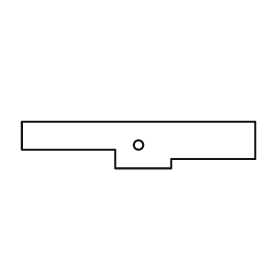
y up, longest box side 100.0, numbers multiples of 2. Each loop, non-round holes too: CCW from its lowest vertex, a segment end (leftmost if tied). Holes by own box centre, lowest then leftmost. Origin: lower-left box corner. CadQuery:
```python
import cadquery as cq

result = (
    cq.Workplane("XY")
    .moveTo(40.0, 0.0)
    .lineTo(64.0, 0.0)
    .lineTo(64.0, 4.0)
    .lineTo(100.0, 4.0)
    .lineTo(100.0, 20.0)
    .lineTo(0.0, 20.0)
    .lineTo(0.0, 8.0)
    .lineTo(40.0, 8.0)
    .close()
    .moveTo(50.0, 10.0)
    .circle(2.0)
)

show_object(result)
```